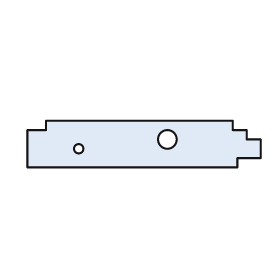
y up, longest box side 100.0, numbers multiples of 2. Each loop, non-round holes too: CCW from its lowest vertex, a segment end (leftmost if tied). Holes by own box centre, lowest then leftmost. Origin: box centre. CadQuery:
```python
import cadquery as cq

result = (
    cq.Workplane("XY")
    .moveTo(-50.0, -10.0)
    .lineTo(40.0, -10.0)
    .lineTo(40.0, -6.0)
    .lineTo(50.0, -6.0)
    .lineTo(50.0, 2.0)
    .lineTo(44.0, 2.0)
    .lineTo(44.0, 6.0)
    .lineTo(38.0, 6.0)
    .lineTo(38.0, 10.0)
    .lineTo(-42.0, 10.0)
    .lineTo(-42.0, 6.0)
    .lineTo(-50.0, 6.0)
    .close()
    .moveTo(-28.0, -2.0)
    .circle(2.0)
    .moveTo(10.0, 2.0)
    .circle(4.0)
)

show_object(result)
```